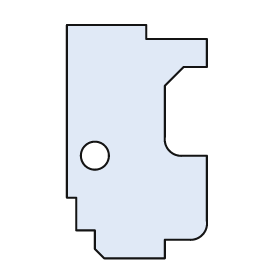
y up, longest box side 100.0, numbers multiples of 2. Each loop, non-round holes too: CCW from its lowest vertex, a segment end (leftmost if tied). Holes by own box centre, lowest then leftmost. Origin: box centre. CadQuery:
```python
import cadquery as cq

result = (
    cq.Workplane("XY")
    .moveTo(-14.0, -50.0)
    .lineTo(12.0, -50.0)
    .lineTo(12.0, -42.0)
    .lineTo(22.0, -42.0)
    .threePointArc((28.0, -40.0), (30.0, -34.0))
    .lineTo(30.0, -6.0)
    .lineTo(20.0, -6.0)
    .threePointArc((14.0, -4.0), (12.0, 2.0))
    .lineTo(12.0, 24.0)
    .lineTo(20.0, 32.0)
    .lineTo(30.0, 32.0)
    .lineTo(30.0, 44.0)
    .lineTo(4.0, 44.0)
    .lineTo(4.0, 50.0)
    .lineTo(-30.0, 50.0)
    .lineTo(-30.0, -24.0)
    .lineTo(-26.0, -24.0)
    .lineTo(-26.0, -38.0)
    .lineTo(-18.0, -38.0)
    .lineTo(-18.0, -46.0)
    .close()
    .moveTo(-18.0, -6.0)
    .circle(6.0)
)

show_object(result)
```